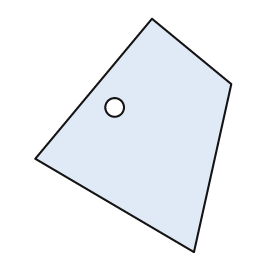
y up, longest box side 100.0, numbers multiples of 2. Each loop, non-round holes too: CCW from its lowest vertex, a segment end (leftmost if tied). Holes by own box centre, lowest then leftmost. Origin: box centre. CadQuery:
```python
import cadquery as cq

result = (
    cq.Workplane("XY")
    .moveTo(26.0, -50.0)
    .lineTo(42.0, 22.0)
    .lineTo(8.0, 50.0)
    .lineTo(-42.0, -10.0)
    .close()
    .moveTo(-8.0, 12.0)
    .circle(4.0)
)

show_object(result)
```